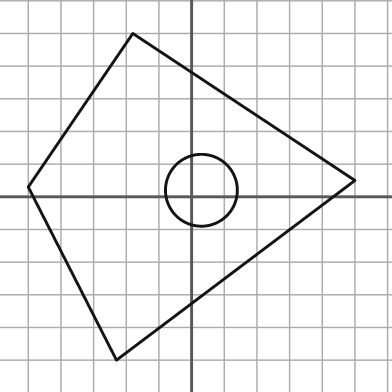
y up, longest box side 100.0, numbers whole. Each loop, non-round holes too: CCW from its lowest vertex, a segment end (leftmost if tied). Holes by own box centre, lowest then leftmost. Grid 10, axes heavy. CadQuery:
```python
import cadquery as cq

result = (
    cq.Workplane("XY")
    .moveTo(-23.0, -50.0)
    .lineTo(50.0, 5.0)
    .lineTo(-18.0, 50.0)
    .lineTo(-50.0, 3.0)
    .close()
    .moveTo(3.0, 2.0)
    .circle(11.0)
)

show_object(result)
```